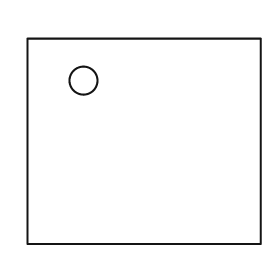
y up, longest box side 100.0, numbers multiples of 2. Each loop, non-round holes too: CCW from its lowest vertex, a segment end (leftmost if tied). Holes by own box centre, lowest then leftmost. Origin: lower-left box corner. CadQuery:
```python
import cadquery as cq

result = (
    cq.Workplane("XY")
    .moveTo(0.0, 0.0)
    .lineTo(100.0, 0.0)
    .lineTo(100.0, 88.0)
    .lineTo(0.0, 88.0)
    .close()
    .moveTo(24.0, 70.0)
    .circle(6.0)
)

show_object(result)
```